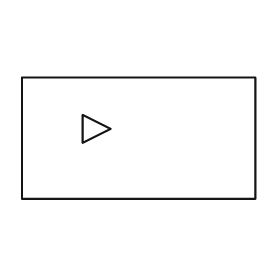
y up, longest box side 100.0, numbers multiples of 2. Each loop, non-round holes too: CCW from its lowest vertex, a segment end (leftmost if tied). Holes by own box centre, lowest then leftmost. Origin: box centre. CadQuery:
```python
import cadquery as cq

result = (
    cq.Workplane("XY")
    .moveTo(-50.0, -26.0)
    .lineTo(50.0, -26.0)
    .lineTo(50.0, 26.0)
    .lineTo(-50.0, 26.0)
    .close()
    .moveTo(-24.0, -2.0)
    .lineTo(-12.0, 4.0)
    .lineTo(-24.0, 10.0)
    .close()
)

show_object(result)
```